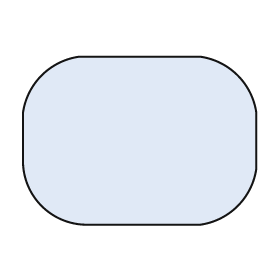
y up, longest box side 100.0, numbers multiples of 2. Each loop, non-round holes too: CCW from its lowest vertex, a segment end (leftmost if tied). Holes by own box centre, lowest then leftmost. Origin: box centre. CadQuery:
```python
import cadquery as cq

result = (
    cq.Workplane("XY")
    .moveTo(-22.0, -36.0)
    .lineTo(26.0, -36.0)
    .threePointArc((42.0, -28.0), (50.0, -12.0))
    .lineTo(50.0, 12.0)
    .threePointArc((42.0, 28.0), (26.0, 36.0))
    .lineTo(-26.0, 36.0)
    .threePointArc((-42.0, 28.0), (-50.0, 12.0))
    .lineTo(-50.0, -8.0)
    .threePointArc((-42.0, -28.0), (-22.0, -36.0))
    .close()
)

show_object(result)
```